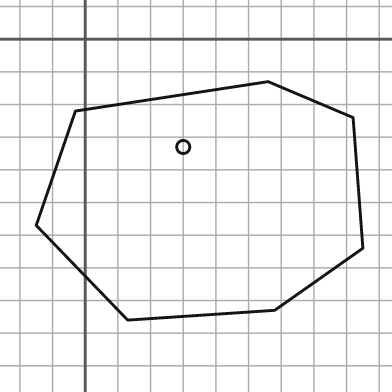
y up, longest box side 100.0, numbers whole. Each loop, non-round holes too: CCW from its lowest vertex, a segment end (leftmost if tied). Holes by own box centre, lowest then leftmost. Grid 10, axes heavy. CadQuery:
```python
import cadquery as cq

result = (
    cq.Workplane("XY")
    .moveTo(13.0, -86.0)
    .lineTo(58.0, -83.0)
    .lineTo(85.0, -64.0)
    .lineTo(82.0, -24.0)
    .lineTo(56.0, -13.0)
    .lineTo(-3.0, -22.0)
    .lineTo(-15.0, -57.0)
    .close()
    .moveTo(30.0, -33.0)
    .circle(2.0)
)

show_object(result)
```